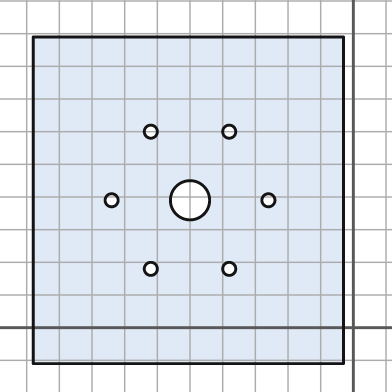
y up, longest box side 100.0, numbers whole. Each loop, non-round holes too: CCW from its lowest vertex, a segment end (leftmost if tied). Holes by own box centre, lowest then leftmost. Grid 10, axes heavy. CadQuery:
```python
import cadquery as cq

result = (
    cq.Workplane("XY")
    .moveTo(-98.0, -11.0)
    .lineTo(-3.0, -11.0)
    .lineTo(-3.0, 89.0)
    .lineTo(-98.0, 89.0)
    .close()
    .moveTo(-62.0, 18.0)
    .circle(2.0)
    .moveTo(-38.0, 18.0)
    .circle(2.0)
    .moveTo(-74.0, 39.0)
    .circle(2.0)
    .moveTo(-50.0, 39.0)
    .circle(6.0)
    .moveTo(-26.0, 39.0)
    .circle(2.0)
    .moveTo(-62.0, 60.0)
    .circle(2.0)
    .moveTo(-38.0, 60.0)
    .circle(2.0)
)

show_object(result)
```